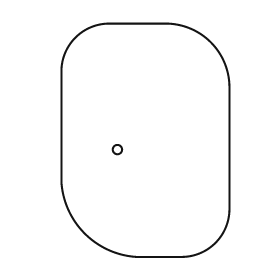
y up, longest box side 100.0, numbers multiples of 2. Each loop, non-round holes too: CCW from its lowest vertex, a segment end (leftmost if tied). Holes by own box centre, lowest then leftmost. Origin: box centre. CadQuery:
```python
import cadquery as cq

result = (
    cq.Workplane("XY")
    .moveTo(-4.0, -50.0)
    .lineTo(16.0, -50.0)
    .threePointArc((30.0, -44.0), (36.0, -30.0))
    .lineTo(36.0, 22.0)
    .threePointArc((28.0, 42.0), (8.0, 50.0))
    .lineTo(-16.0, 50.0)
    .threePointArc((-30.0, 44.0), (-36.0, 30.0))
    .lineTo(-36.0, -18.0)
    .threePointArc((-26.0, -40.0), (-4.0, -50.0))
    .close()
    .moveTo(-12.0, -4.0)
    .circle(2.0)
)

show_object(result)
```